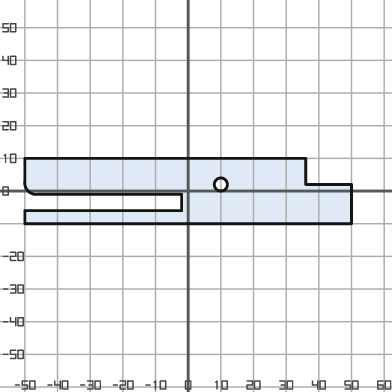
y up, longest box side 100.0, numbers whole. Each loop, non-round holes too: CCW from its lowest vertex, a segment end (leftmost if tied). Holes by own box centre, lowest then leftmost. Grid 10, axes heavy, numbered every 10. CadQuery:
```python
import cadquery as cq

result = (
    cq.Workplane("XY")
    .moveTo(-50.0, -10.0)
    .lineTo(50.0, -10.0)
    .lineTo(50.0, 2.0)
    .lineTo(36.0, 2.0)
    .lineTo(36.0, 10.0)
    .lineTo(-50.0, 10.0)
    .lineTo(-50.0, 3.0)
    .threePointArc((-49.0, 0.0), (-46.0, -1.0))
    .lineTo(-2.0, -1.0)
    .lineTo(-2.0, -6.0)
    .lineTo(-50.0, -6.0)
    .close()
    .moveTo(10.0, 2.0)
    .circle(2.0)
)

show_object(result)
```